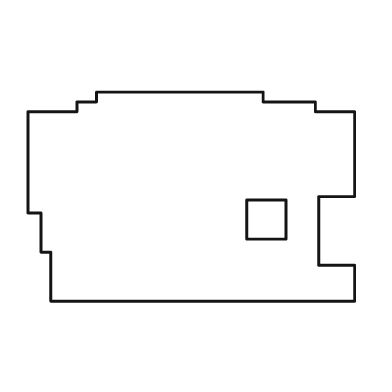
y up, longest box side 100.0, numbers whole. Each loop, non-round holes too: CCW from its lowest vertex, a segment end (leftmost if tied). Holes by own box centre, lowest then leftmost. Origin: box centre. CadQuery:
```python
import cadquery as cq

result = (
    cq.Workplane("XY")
    .moveTo(-43.0, -32.0)
    .lineTo(50.0, -32.0)
    .lineTo(50.0, -21.0)
    .lineTo(39.0, -21.0)
    .lineTo(39.0, 0.0)
    .lineTo(50.0, 0.0)
    .lineTo(50.0, 26.0)
    .lineTo(38.0, 26.0)
    .lineTo(38.0, 29.0)
    .lineTo(22.0, 29.0)
    .lineTo(22.0, 32.0)
    .lineTo(-29.0, 32.0)
    .lineTo(-29.0, 29.0)
    .lineTo(-35.0, 29.0)
    .lineTo(-35.0, 26.0)
    .lineTo(-50.0, 26.0)
    .lineTo(-50.0, -5.0)
    .lineTo(-46.0, -5.0)
    .lineTo(-46.0, -17.0)
    .lineTo(-43.0, -17.0)
    .close()
    .moveTo(17.0, -13.0)
    .lineTo(29.0, -13.0)
    .lineTo(29.0, -1.0)
    .lineTo(17.0, -1.0)
    .close()
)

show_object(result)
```